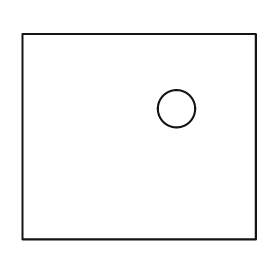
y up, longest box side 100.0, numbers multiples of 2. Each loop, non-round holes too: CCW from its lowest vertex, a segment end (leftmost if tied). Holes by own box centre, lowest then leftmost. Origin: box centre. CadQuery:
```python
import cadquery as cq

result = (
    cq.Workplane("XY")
    .moveTo(-50.0, -44.0)
    .lineTo(50.0, -44.0)
    .lineTo(50.0, 44.0)
    .lineTo(-50.0, 44.0)
    .close()
    .moveTo(16.0, 12.0)
    .circle(8.0)
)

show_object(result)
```